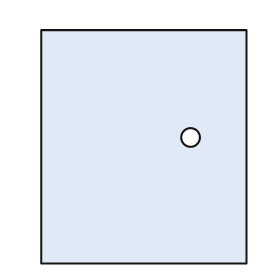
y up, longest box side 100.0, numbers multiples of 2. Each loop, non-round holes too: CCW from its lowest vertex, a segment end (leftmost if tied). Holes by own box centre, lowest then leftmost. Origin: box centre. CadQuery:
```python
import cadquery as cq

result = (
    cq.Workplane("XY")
    .moveTo(-44.0, -50.0)
    .lineTo(44.0, -50.0)
    .lineTo(44.0, 50.0)
    .lineTo(-44.0, 50.0)
    .close()
    .moveTo(20.0, 4.0)
    .circle(4.0)
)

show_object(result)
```